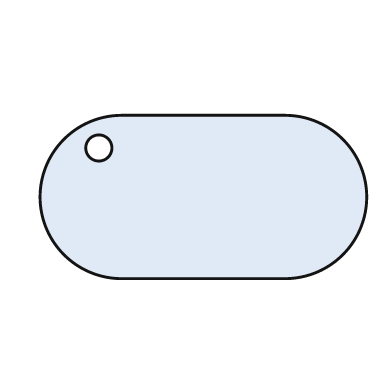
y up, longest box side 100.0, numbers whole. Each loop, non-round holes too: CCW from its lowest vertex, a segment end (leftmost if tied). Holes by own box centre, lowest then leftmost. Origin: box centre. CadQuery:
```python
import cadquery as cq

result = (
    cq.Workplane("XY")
    .moveTo(-25.0, -25.0)
    .lineTo(25.0, -25.0)
    .threePointArc((50.0, 0.0), (25.0, 25.0))
    .lineTo(-25.0, 25.0)
    .threePointArc((-50.0, 0.0), (-25.0, -25.0))
    .close()
    .moveTo(-32.0, 15.0)
    .circle(4.0)
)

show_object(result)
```